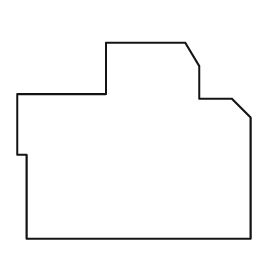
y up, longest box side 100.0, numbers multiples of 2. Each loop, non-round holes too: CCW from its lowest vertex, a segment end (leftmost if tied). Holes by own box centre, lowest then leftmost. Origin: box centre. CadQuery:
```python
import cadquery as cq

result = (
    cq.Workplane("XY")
    .moveTo(-46.0, -42.0)
    .lineTo(50.0, -42.0)
    .lineTo(50.0, 10.0)
    .lineTo(42.0, 18.0)
    .lineTo(28.0, 18.0)
    .lineTo(28.0, 32.0)
    .lineTo(22.0, 42.0)
    .lineTo(-12.0, 42.0)
    .lineTo(-12.0, 20.0)
    .lineTo(-50.0, 20.0)
    .lineTo(-50.0, -6.0)
    .lineTo(-46.0, -6.0)
    .close()
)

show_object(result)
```